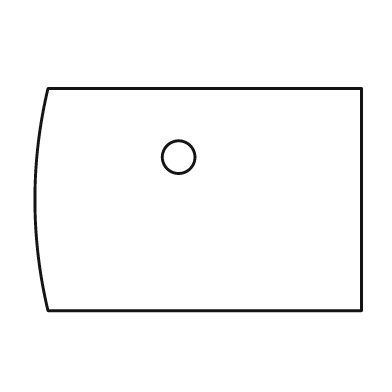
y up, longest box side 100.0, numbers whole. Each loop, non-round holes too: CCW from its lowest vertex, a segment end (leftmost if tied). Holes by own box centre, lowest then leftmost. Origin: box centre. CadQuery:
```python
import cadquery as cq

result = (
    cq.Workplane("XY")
    .moveTo(-46.0, -34.0)
    .lineTo(50.0, -34.0)
    .lineTo(50.0, 34.0)
    .lineTo(-46.0, 34.0)
    .threePointArc((-50.0, 0.0), (-46.0, -34.0))
    .close()
    .moveTo(-6.0, 13.0)
    .circle(5.0)
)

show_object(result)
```